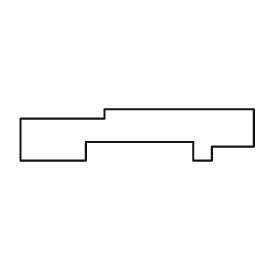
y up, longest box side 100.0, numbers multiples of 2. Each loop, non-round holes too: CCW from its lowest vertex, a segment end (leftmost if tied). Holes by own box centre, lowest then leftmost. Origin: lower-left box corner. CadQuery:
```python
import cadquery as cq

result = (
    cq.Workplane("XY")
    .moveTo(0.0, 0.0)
    .lineTo(28.0, 0.0)
    .lineTo(28.0, 8.0)
    .lineTo(74.0, 8.0)
    .lineTo(74.0, 0.0)
    .lineTo(82.0, 0.0)
    .lineTo(82.0, 6.0)
    .lineTo(100.0, 6.0)
    .lineTo(100.0, 22.0)
    .lineTo(36.0, 22.0)
    .lineTo(36.0, 18.0)
    .lineTo(0.0, 18.0)
    .close()
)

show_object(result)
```